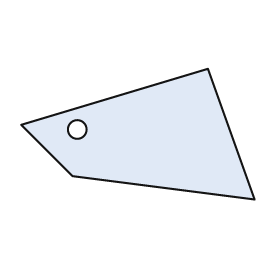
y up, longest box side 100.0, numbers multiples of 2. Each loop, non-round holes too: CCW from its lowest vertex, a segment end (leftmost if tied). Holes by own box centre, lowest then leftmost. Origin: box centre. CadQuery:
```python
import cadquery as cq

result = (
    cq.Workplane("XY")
    .moveTo(50.0, -28.0)
    .lineTo(30.0, 28.0)
    .lineTo(-50.0, 4.0)
    .lineTo(-28.0, -18.0)
    .close()
    .moveTo(-26.0, 2.0)
    .circle(4.0)
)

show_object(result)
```